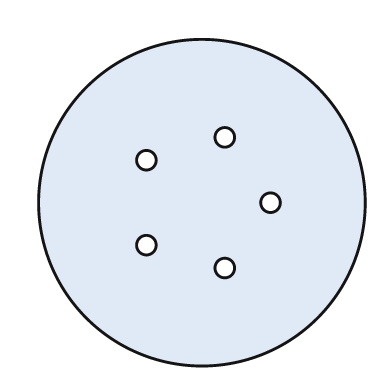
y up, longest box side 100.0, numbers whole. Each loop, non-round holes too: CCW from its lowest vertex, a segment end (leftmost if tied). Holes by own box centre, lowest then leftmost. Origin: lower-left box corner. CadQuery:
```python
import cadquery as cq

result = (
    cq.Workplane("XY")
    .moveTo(50.0, 50.0)
    .circle(50.0)
    .moveTo(57.0, 30.0)
    .circle(3.0)
    .moveTo(33.0, 37.0)
    .circle(3.0)
    .moveTo(71.0, 50.0)
    .circle(3.0)
    .moveTo(33.0, 63.0)
    .circle(3.0)
    .moveTo(57.0, 70.0)
    .circle(3.0)
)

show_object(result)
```